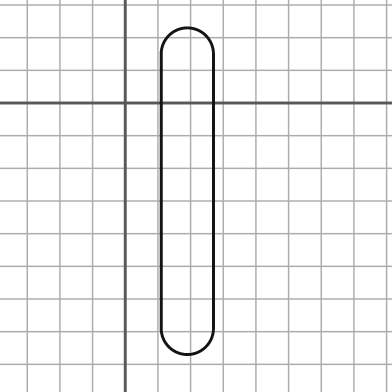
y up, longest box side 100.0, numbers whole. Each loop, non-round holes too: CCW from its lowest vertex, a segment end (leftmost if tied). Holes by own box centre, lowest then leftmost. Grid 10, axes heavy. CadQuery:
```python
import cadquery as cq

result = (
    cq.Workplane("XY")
    .moveTo(11.0, -69.0)
    .threePointArc((19.0, -77.0), (27.0, -69.0))
    .lineTo(27.0, 15.0)
    .threePointArc((19.0, 23.0), (11.0, 15.0))
    .close()
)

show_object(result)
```